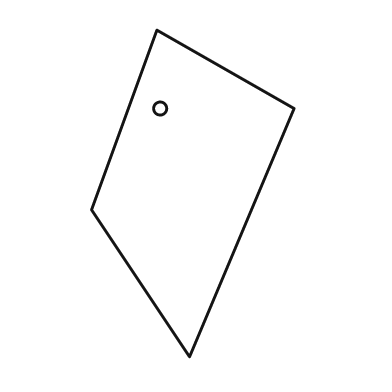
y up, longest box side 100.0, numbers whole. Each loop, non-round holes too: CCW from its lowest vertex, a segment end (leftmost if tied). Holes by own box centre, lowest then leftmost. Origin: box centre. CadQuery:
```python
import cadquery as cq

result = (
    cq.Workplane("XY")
    .moveTo(-1.0, -50.0)
    .lineTo(31.0, 26.0)
    .lineTo(-11.0, 50.0)
    .lineTo(-31.0, -5.0)
    .close()
    .moveTo(-10.0, 26.0)
    .circle(2.0)
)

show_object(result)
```